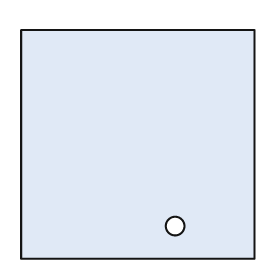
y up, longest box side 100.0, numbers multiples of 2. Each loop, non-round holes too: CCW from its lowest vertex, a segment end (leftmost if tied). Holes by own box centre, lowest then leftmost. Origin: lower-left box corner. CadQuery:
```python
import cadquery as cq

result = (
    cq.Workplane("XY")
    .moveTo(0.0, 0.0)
    .lineTo(100.0, 0.0)
    .lineTo(100.0, 98.0)
    .lineTo(0.0, 98.0)
    .close()
    .moveTo(66.0, 14.0)
    .circle(4.0)
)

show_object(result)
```